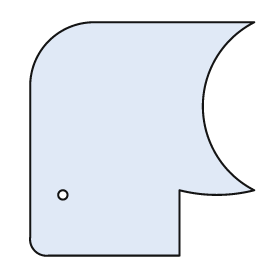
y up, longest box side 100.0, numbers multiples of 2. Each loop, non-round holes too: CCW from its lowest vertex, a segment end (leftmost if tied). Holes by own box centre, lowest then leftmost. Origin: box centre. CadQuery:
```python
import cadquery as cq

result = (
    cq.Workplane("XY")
    .moveTo(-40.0, -50.0)
    .lineTo(16.0, -50.0)
    .lineTo(16.0, -22.0)
    .threePointArc((32.0, -24.0), (48.0, -22.0))
    .threePointArc((26.0, 14.0), (48.0, 50.0))
    .lineTo(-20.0, 50.0)
    .threePointArc((-40.0, 42.0), (-48.0, 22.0))
    .lineTo(-48.0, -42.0)
    .threePointArc((-46.0, -48.0), (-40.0, -50.0))
    .close()
    .moveTo(-34.0, -24.0)
    .circle(2.0)
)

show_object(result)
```